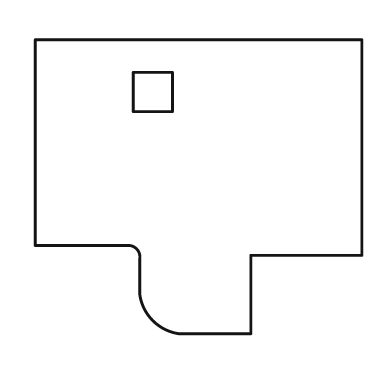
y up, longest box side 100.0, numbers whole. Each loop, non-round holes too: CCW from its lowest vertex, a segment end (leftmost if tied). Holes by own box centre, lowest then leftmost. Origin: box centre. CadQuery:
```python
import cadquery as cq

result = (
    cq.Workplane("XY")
    .moveTo(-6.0, -45.0)
    .lineTo(16.0, -45.0)
    .lineTo(16.0, -21.0)
    .lineTo(50.0, -21.0)
    .lineTo(50.0, 45.0)
    .lineTo(-50.0, 45.0)
    .lineTo(-50.0, -18.0)
    .lineTo(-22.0, -18.0)
    .threePointArc((-19.0, -19.0), (-18.0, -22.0))
    .lineTo(-18.0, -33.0)
    .threePointArc((-14.0, -41.0), (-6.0, -45.0))
    .close()
    .moveTo(-20.0, 23.0)
    .lineTo(-8.0, 23.0)
    .lineTo(-8.0, 35.0)
    .lineTo(-20.0, 35.0)
    .close()
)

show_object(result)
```